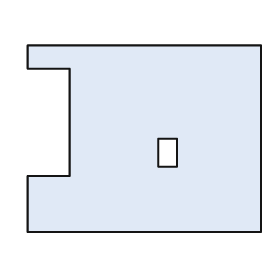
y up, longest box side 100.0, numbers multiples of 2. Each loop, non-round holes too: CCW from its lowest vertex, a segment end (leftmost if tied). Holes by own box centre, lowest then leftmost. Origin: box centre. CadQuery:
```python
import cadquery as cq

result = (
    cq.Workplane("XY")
    .moveTo(-50.0, -40.0)
    .lineTo(50.0, -40.0)
    .lineTo(50.0, 40.0)
    .lineTo(-50.0, 40.0)
    .lineTo(-50.0, 30.0)
    .lineTo(-32.0, 30.0)
    .lineTo(-32.0, -16.0)
    .lineTo(-50.0, -16.0)
    .close()
    .moveTo(6.0, -12.0)
    .lineTo(14.0, -12.0)
    .lineTo(14.0, 0.0)
    .lineTo(6.0, 0.0)
    .close()
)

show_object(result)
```